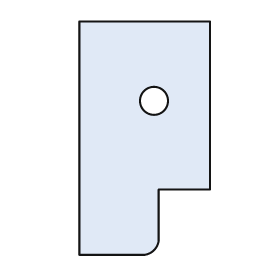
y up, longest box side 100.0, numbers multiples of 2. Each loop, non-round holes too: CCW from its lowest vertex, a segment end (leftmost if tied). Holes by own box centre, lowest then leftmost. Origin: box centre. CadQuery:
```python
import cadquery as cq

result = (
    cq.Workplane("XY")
    .moveTo(-28.0, -50.0)
    .lineTo(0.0, -50.0)
    .threePointArc((4.0, -48.0), (6.0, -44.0))
    .lineTo(6.0, -22.0)
    .lineTo(28.0, -22.0)
    .lineTo(28.0, 50.0)
    .lineTo(-28.0, 50.0)
    .close()
    .moveTo(4.0, 16.0)
    .circle(6.0)
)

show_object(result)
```